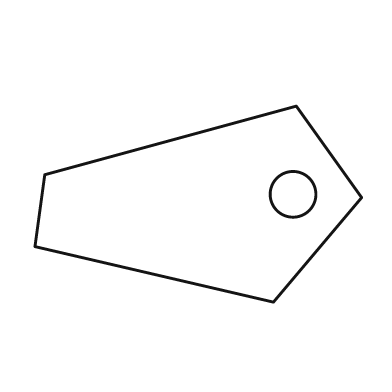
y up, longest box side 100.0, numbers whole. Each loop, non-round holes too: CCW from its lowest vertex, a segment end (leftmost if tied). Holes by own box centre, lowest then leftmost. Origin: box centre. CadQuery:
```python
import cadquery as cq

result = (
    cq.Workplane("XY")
    .moveTo(23.0, -30.0)
    .lineTo(50.0, 2.0)
    .lineTo(30.0, 30.0)
    .lineTo(-47.0, 9.0)
    .lineTo(-50.0, -13.0)
    .close()
    .moveTo(29.0, 3.0)
    .circle(7.0)
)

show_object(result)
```